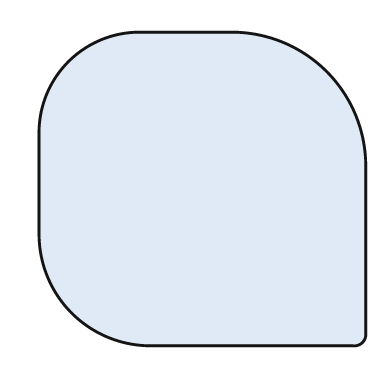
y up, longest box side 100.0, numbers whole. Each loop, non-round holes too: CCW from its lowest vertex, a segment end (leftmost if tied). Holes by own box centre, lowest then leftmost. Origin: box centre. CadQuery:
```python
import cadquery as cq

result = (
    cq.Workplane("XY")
    .moveTo(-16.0, -48.0)
    .lineTo(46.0, -48.0)
    .threePointArc((49.0, -47.0), (50.0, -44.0))
    .lineTo(50.0, 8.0)
    .threePointArc((38.0, 36.0), (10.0, 48.0))
    .lineTo(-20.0, 48.0)
    .threePointArc((-41.0, 39.0), (-50.0, 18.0))
    .lineTo(-50.0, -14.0)
    .threePointArc((-40.0, -38.0), (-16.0, -48.0))
    .close()
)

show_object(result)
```